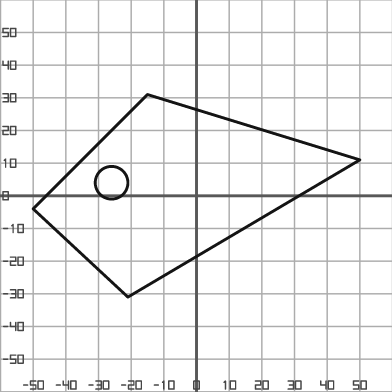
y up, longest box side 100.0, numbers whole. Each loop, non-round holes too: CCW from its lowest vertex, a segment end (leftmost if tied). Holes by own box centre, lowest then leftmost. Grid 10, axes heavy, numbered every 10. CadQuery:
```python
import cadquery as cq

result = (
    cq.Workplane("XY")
    .moveTo(-21.0, -31.0)
    .lineTo(50.0, 11.0)
    .lineTo(-15.0, 31.0)
    .lineTo(-50.0, -4.0)
    .close()
    .moveTo(-26.0, 4.0)
    .circle(5.0)
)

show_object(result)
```